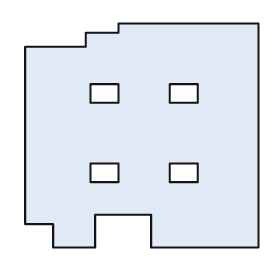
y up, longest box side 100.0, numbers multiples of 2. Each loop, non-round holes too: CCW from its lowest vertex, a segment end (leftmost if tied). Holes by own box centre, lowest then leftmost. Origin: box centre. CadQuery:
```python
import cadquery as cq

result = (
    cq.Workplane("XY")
    .moveTo(-38.0, -48.0)
    .lineTo(-20.0, -48.0)
    .lineTo(-20.0, -34.0)
    .lineTo(4.0, -34.0)
    .lineTo(4.0, -48.0)
    .lineTo(50.0, -48.0)
    .lineTo(50.0, 48.0)
    .lineTo(-10.0, 48.0)
    .lineTo(-10.0, 44.0)
    .lineTo(-24.0, 44.0)
    .lineTo(-24.0, 38.0)
    .lineTo(-50.0, 38.0)
    .lineTo(-50.0, -38.0)
    .lineTo(-38.0, -38.0)
    .close()
    .moveTo(-22.0, -20.0)
    .lineTo(-10.0, -20.0)
    .lineTo(-10.0, -12.0)
    .lineTo(-22.0, -12.0)
    .close()
    .moveTo(12.0, -20.0)
    .lineTo(24.0, -20.0)
    .lineTo(24.0, -12.0)
    .lineTo(12.0, -12.0)
    .close()
    .moveTo(-22.0, 14.0)
    .lineTo(-10.0, 14.0)
    .lineTo(-10.0, 22.0)
    .lineTo(-22.0, 22.0)
    .close()
    .moveTo(12.0, 14.0)
    .lineTo(24.0, 14.0)
    .lineTo(24.0, 22.0)
    .lineTo(12.0, 22.0)
    .close()
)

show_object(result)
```